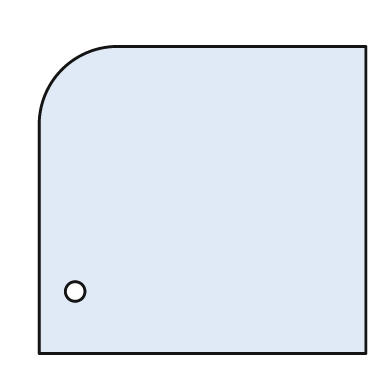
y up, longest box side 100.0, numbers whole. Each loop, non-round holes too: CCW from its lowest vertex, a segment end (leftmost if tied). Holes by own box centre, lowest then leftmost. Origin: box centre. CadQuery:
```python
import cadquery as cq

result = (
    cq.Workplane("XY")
    .moveTo(-50.0, -47.0)
    .lineTo(50.0, -47.0)
    .lineTo(50.0, 47.0)
    .lineTo(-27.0, 47.0)
    .threePointArc((-43.0, 40.0), (-50.0, 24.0))
    .close()
    .moveTo(-39.0, -28.0)
    .circle(3.0)
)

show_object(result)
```